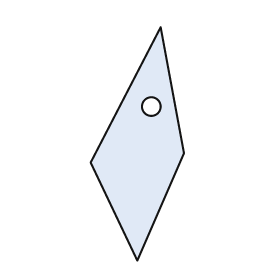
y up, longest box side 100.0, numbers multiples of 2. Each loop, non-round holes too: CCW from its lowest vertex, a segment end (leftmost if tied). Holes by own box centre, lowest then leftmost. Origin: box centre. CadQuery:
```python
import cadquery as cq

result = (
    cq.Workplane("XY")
    .moveTo(0.0, -50.0)
    .lineTo(20.0, -4.0)
    .lineTo(10.0, 50.0)
    .lineTo(-20.0, -8.0)
    .close()
    .moveTo(6.0, 16.0)
    .circle(4.0)
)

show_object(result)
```